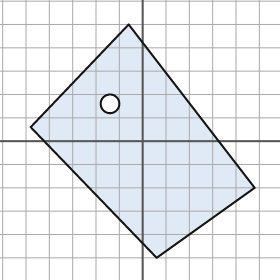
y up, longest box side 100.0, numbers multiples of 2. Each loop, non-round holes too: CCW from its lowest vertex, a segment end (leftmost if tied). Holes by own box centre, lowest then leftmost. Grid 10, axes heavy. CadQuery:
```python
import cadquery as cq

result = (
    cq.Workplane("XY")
    .moveTo(6.0, -50.0)
    .lineTo(48.0, -20.0)
    .lineTo(-6.0, 50.0)
    .lineTo(-48.0, 6.0)
    .close()
    .moveTo(-14.0, 16.0)
    .circle(4.0)
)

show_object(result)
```